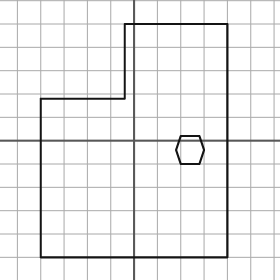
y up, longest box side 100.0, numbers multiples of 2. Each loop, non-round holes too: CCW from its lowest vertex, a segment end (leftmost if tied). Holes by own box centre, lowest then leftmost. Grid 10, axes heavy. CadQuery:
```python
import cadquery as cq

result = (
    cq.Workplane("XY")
    .moveTo(-40.0, -50.0)
    .lineTo(40.0, -50.0)
    .lineTo(40.0, 50.0)
    .lineTo(-4.0, 50.0)
    .lineTo(-4.0, 18.0)
    .lineTo(-40.0, 18.0)
    .close()
    .moveTo(20.0, -10.0)
    .lineTo(28.0, -10.0)
    .lineTo(30.0, -4.0)
    .lineTo(28.0, 2.0)
    .lineTo(20.0, 2.0)
    .lineTo(18.0, -4.0)
    .close()
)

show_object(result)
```